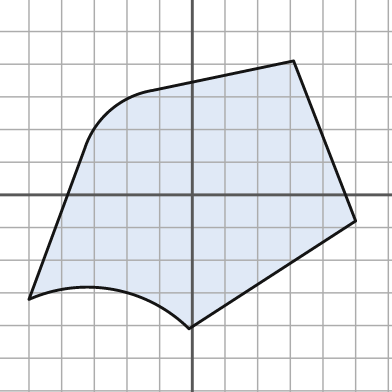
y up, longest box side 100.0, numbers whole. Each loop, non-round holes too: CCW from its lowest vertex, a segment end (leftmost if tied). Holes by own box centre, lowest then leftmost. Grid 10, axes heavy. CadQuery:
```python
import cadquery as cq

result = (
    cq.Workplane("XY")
    .moveTo(-1.0, -41.0)
    .lineTo(50.0, -8.0)
    .lineTo(31.0, 41.0)
    .lineTo(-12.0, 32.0)
    .threePointArc((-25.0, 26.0), (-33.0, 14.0))
    .lineTo(-50.0, -32.0)
    .threePointArc((-24.0, -29.0), (-1.0, -41.0))
    .close()
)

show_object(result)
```